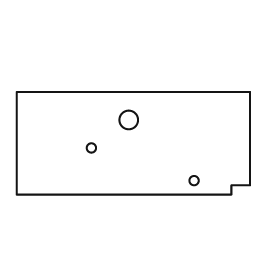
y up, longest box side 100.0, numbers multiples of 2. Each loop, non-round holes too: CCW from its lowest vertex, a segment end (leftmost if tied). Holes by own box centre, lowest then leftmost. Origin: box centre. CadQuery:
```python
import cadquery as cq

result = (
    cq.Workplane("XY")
    .moveTo(-50.0, -22.0)
    .lineTo(42.0, -22.0)
    .lineTo(42.0, -18.0)
    .lineTo(50.0, -18.0)
    .lineTo(50.0, 22.0)
    .lineTo(-50.0, 22.0)
    .close()
    .moveTo(26.0, -16.0)
    .circle(2.0)
    .moveTo(-18.0, -2.0)
    .circle(2.0)
    .moveTo(-2.0, 10.0)
    .circle(4.0)
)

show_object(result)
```